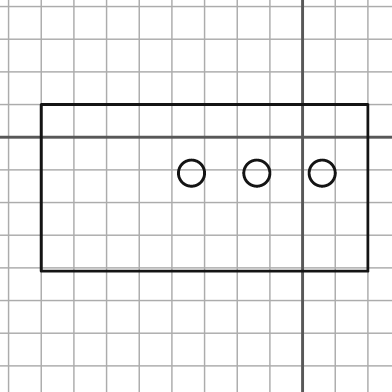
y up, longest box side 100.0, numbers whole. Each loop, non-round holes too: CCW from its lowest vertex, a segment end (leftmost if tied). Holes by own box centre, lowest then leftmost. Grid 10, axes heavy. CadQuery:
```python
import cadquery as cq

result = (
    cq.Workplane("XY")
    .moveTo(-80.0, -41.0)
    .lineTo(20.0, -41.0)
    .lineTo(20.0, 10.0)
    .lineTo(-80.0, 10.0)
    .close()
    .moveTo(-34.0, -11.0)
    .circle(4.0)
    .moveTo(-14.0, -11.0)
    .circle(4.0)
    .moveTo(6.0, -11.0)
    .circle(4.0)
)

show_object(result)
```